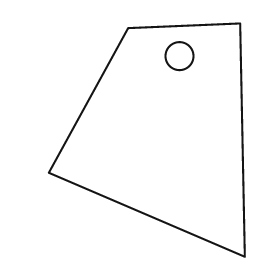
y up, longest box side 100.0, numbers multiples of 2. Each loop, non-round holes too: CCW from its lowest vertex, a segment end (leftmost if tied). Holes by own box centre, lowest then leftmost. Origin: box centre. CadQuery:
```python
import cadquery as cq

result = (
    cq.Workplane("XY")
    .moveTo(42.0, -50.0)
    .lineTo(40.0, 50.0)
    .lineTo(-8.0, 48.0)
    .lineTo(-42.0, -14.0)
    .close()
    .moveTo(14.0, 36.0)
    .circle(6.0)
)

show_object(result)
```